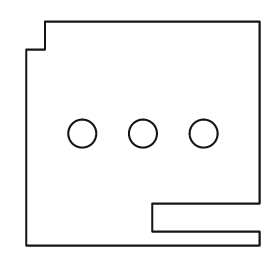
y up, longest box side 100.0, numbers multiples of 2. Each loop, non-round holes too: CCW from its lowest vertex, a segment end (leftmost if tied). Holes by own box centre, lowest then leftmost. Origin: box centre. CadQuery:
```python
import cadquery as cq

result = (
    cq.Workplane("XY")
    .moveTo(-50.0, -48.0)
    .lineTo(50.0, -48.0)
    .lineTo(50.0, -42.0)
    .lineTo(4.0, -42.0)
    .lineTo(4.0, -30.0)
    .lineTo(50.0, -30.0)
    .lineTo(50.0, 48.0)
    .lineTo(-42.0, 48.0)
    .lineTo(-42.0, 36.0)
    .lineTo(-50.0, 36.0)
    .close()
    .moveTo(-26.0, 0.0)
    .circle(6.0)
    .moveTo(0.0, 0.0)
    .circle(6.0)
    .moveTo(26.0, 0.0)
    .circle(6.0)
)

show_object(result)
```